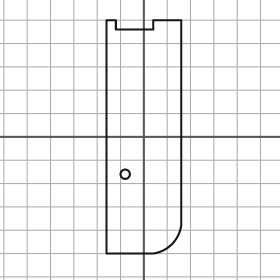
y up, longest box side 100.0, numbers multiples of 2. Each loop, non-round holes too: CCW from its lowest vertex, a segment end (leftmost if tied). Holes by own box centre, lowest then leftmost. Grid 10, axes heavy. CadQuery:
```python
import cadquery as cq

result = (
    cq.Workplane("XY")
    .moveTo(-16.0, -50.0)
    .lineTo(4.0, -50.0)
    .threePointArc((12.0, -46.0), (16.0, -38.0))
    .lineTo(16.0, 50.0)
    .lineTo(4.0, 50.0)
    .lineTo(4.0, 46.0)
    .lineTo(-12.0, 46.0)
    .lineTo(-12.0, 50.0)
    .lineTo(-16.0, 50.0)
    .close()
    .moveTo(-8.0, -16.0)
    .circle(2.0)
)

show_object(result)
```